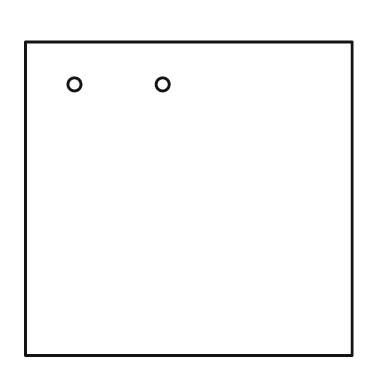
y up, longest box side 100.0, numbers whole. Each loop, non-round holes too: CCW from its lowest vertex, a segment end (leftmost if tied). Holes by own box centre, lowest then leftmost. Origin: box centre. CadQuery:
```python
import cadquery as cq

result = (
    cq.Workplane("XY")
    .moveTo(-50.0, -48.0)
    .lineTo(50.0, -48.0)
    .lineTo(50.0, 48.0)
    .lineTo(-50.0, 48.0)
    .close()
    .moveTo(-35.0, 35.0)
    .circle(2.0)
    .moveTo(-8.0, 35.0)
    .circle(2.0)
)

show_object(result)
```